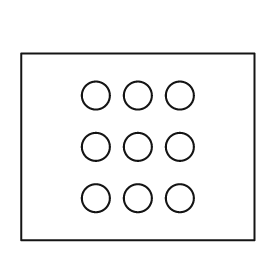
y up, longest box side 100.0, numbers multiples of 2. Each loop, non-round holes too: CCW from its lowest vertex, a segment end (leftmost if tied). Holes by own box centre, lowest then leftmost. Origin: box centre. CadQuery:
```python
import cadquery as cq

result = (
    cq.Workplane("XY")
    .moveTo(-50.0, -40.0)
    .lineTo(50.0, -40.0)
    .lineTo(50.0, 40.0)
    .lineTo(-50.0, 40.0)
    .close()
    .moveTo(-18.0, -22.0)
    .circle(6.0)
    .moveTo(0.0, -22.0)
    .circle(6.0)
    .moveTo(18.0, -22.0)
    .circle(6.0)
    .moveTo(-18.0, 0.0)
    .circle(6.0)
    .moveTo(0.0, 0.0)
    .circle(6.0)
    .moveTo(18.0, 0.0)
    .circle(6.0)
    .moveTo(-18.0, 22.0)
    .circle(6.0)
    .moveTo(0.0, 22.0)
    .circle(6.0)
    .moveTo(18.0, 22.0)
    .circle(6.0)
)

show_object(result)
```